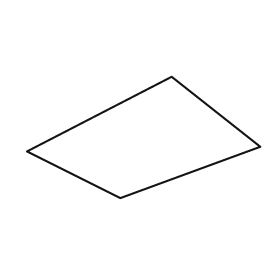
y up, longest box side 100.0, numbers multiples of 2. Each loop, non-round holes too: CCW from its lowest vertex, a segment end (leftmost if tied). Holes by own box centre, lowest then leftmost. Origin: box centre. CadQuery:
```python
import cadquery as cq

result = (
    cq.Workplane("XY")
    .moveTo(-10.0, -26.0)
    .lineTo(50.0, -4.0)
    .lineTo(12.0, 26.0)
    .lineTo(-50.0, -6.0)
    .close()
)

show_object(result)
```